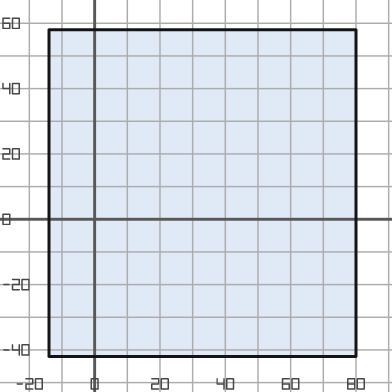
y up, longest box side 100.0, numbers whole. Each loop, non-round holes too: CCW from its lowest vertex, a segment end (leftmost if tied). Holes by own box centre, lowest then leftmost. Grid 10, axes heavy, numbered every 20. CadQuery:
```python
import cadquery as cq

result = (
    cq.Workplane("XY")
    .moveTo(-14.0, -42.0)
    .lineTo(80.0, -42.0)
    .lineTo(80.0, 58.0)
    .lineTo(-14.0, 58.0)
    .close()
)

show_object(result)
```